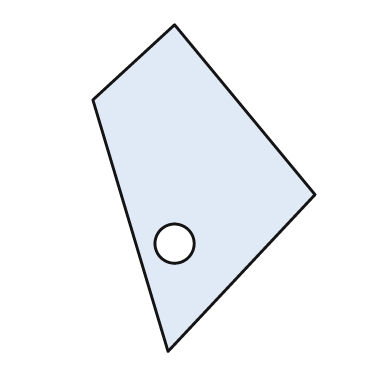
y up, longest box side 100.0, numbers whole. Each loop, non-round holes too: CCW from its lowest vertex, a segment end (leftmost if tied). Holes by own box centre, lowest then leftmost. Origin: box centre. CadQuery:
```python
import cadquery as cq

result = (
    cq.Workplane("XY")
    .moveTo(-11.0, -50.0)
    .lineTo(34.0, -2.0)
    .lineTo(-9.0, 50.0)
    .lineTo(-34.0, 27.0)
    .close()
    .moveTo(-9.0, -17.0)
    .circle(6.0)
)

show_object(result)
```